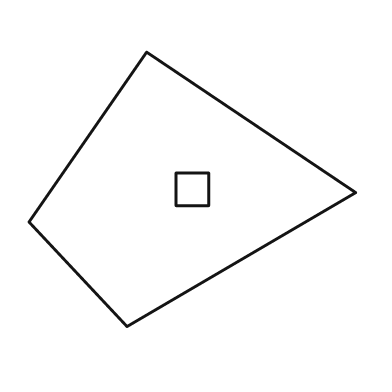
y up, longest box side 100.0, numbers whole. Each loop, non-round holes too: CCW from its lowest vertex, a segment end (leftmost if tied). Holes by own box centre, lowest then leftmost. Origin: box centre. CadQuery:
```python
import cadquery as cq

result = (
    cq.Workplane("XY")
    .moveTo(-20.0, -42.0)
    .lineTo(50.0, -1.0)
    .lineTo(-14.0, 42.0)
    .lineTo(-50.0, -10.0)
    .close()
    .moveTo(-5.0, -5.0)
    .lineTo(5.0, -5.0)
    .lineTo(5.0, 5.0)
    .lineTo(-5.0, 5.0)
    .close()
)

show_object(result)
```